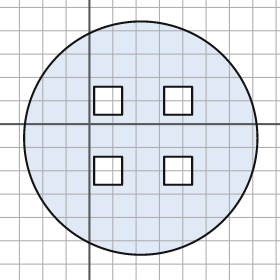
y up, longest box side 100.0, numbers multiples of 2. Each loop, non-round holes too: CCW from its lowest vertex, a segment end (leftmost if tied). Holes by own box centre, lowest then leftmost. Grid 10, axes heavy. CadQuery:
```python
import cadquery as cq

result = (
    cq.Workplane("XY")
    .moveTo(22.0, -6.0)
    .circle(50.0)
    .moveTo(2.0, -26.0)
    .lineTo(14.0, -26.0)
    .lineTo(14.0, -14.0)
    .lineTo(2.0, -14.0)
    .close()
    .moveTo(32.0, -26.0)
    .lineTo(44.0, -26.0)
    .lineTo(44.0, -14.0)
    .lineTo(32.0, -14.0)
    .close()
    .moveTo(2.0, 4.0)
    .lineTo(14.0, 4.0)
    .lineTo(14.0, 16.0)
    .lineTo(2.0, 16.0)
    .close()
    .moveTo(32.0, 4.0)
    .lineTo(44.0, 4.0)
    .lineTo(44.0, 16.0)
    .lineTo(32.0, 16.0)
    .close()
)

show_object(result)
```